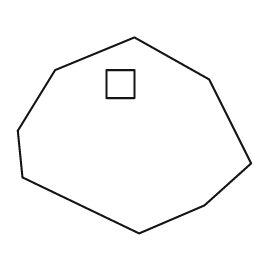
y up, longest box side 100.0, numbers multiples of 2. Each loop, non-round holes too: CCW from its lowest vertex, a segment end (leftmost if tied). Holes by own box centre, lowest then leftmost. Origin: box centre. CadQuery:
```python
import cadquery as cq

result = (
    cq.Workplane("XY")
    .moveTo(2.0, -42.0)
    .lineTo(30.0, -30.0)
    .lineTo(50.0, -12.0)
    .lineTo(32.0, 24.0)
    .lineTo(0.0, 42.0)
    .lineTo(-34.0, 28.0)
    .lineTo(-50.0, 2.0)
    .lineTo(-48.0, -18.0)
    .close()
    .moveTo(-12.0, 16.0)
    .lineTo(0.0, 16.0)
    .lineTo(0.0, 28.0)
    .lineTo(-12.0, 28.0)
    .close()
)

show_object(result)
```